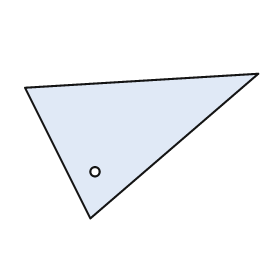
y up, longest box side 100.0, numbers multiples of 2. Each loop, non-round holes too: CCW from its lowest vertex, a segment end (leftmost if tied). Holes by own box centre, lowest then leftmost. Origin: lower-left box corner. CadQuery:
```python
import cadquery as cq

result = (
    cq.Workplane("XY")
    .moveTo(28.0, 0.0)
    .lineTo(100.0, 62.0)
    .lineTo(0.0, 56.0)
    .close()
    .moveTo(30.0, 20.0)
    .circle(2.0)
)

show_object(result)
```